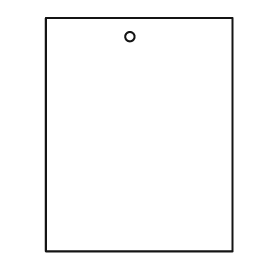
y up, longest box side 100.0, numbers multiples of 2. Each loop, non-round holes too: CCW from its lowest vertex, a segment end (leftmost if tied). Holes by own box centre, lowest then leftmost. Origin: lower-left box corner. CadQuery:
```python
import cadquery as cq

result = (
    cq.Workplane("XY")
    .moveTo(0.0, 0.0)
    .lineTo(80.0, 0.0)
    .lineTo(80.0, 100.0)
    .lineTo(0.0, 100.0)
    .close()
    .moveTo(36.0, 92.0)
    .circle(2.0)
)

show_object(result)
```